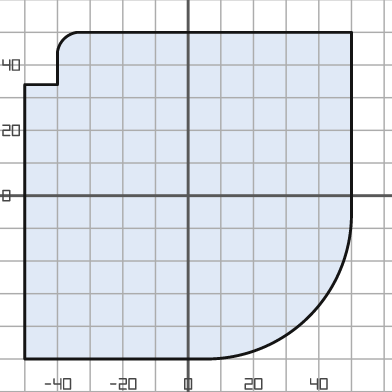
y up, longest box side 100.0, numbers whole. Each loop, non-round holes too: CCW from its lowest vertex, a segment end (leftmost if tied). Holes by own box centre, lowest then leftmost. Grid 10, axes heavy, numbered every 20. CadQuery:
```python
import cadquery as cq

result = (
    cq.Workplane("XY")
    .moveTo(-50.0, -50.0)
    .lineTo(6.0, -50.0)
    .threePointArc((37.0, -37.0), (50.0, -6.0))
    .lineTo(50.0, 50.0)
    .lineTo(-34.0, 50.0)
    .threePointArc((-38.0, 48.0), (-40.0, 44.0))
    .lineTo(-40.0, 34.0)
    .lineTo(-50.0, 34.0)
    .close()
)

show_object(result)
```